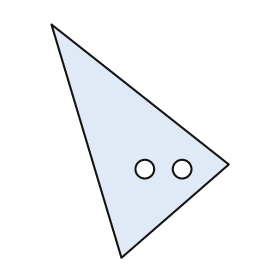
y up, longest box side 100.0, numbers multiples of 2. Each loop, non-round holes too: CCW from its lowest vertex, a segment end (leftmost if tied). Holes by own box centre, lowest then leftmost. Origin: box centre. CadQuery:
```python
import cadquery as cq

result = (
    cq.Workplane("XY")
    .moveTo(-8.0, -50.0)
    .lineTo(38.0, -10.0)
    .lineTo(-38.0, 50.0)
    .close()
    .moveTo(2.0, -12.0)
    .circle(4.0)
    .moveTo(18.0, -12.0)
    .circle(4.0)
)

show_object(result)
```